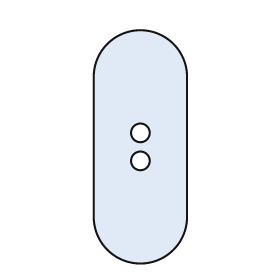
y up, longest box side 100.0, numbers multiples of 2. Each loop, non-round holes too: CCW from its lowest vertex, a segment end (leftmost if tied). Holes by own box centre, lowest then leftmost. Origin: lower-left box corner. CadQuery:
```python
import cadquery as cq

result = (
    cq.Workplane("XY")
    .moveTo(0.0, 20.0)
    .threePointArc((20.0, 0.0), (40.0, 20.0))
    .lineTo(40.0, 80.0)
    .threePointArc((20.0, 100.0), (0.0, 80.0))
    .close()
    .moveTo(20.0, 44.0)
    .circle(4.0)
    .moveTo(20.0, 56.0)
    .circle(4.0)
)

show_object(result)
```